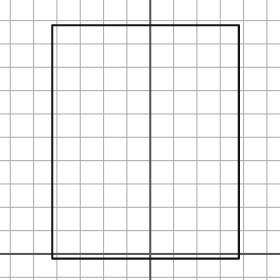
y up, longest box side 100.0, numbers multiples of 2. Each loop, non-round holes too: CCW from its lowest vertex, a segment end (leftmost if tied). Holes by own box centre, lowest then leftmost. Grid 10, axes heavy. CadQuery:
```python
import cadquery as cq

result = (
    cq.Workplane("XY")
    .moveTo(-42.0, -2.0)
    .lineTo(38.0, -2.0)
    .lineTo(38.0, 98.0)
    .lineTo(-42.0, 98.0)
    .close()
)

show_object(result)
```